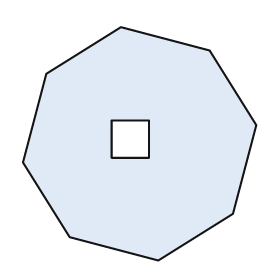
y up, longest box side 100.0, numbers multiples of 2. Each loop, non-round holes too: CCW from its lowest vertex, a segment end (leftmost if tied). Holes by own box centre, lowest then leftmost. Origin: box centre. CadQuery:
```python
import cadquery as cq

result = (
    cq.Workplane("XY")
    .moveTo(8.0, -50.0)
    .lineTo(40.0, -30.0)
    .lineTo(50.0, 8.0)
    .lineTo(30.0, 40.0)
    .lineTo(-8.0, 50.0)
    .lineTo(-40.0, 30.0)
    .lineTo(-50.0, -8.0)
    .lineTo(-30.0, -40.0)
    .close()
    .moveTo(-12.0, -6.0)
    .lineTo(4.0, -6.0)
    .lineTo(4.0, 10.0)
    .lineTo(-12.0, 10.0)
    .close()
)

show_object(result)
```